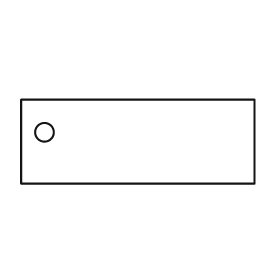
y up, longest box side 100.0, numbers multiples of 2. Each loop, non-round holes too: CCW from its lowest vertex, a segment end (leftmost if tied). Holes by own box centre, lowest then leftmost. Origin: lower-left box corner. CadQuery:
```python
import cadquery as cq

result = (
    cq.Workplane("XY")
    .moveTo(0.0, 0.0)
    .lineTo(100.0, 0.0)
    .lineTo(100.0, 36.0)
    .lineTo(0.0, 36.0)
    .close()
    .moveTo(10.0, 22.0)
    .circle(4.0)
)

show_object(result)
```